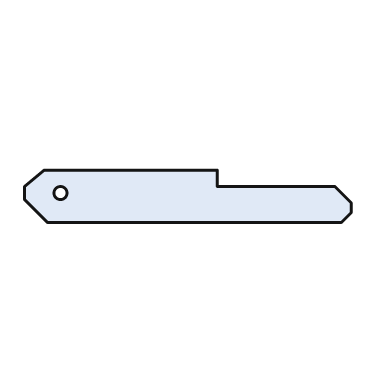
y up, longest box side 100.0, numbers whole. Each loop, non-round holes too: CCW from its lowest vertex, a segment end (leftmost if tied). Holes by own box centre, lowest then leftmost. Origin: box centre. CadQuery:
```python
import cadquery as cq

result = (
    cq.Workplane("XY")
    .moveTo(-43.0, -8.0)
    .lineTo(47.0, -8.0)
    .lineTo(50.0, -5.0)
    .lineTo(50.0, -2.0)
    .lineTo(45.0, 3.0)
    .lineTo(9.0, 3.0)
    .lineTo(9.0, 8.0)
    .lineTo(-44.0, 8.0)
    .lineTo(-50.0, 3.0)
    .lineTo(-50.0, -1.0)
    .close()
    .moveTo(-39.0, 1.0)
    .circle(2.0)
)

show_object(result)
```